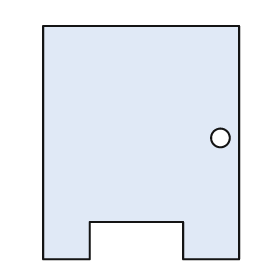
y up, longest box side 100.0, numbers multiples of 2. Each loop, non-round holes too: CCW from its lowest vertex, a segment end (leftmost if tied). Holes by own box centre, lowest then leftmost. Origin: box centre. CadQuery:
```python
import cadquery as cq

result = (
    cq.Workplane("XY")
    .moveTo(-42.0, -50.0)
    .lineTo(-22.0, -50.0)
    .lineTo(-22.0, -34.0)
    .lineTo(18.0, -34.0)
    .lineTo(18.0, -50.0)
    .lineTo(42.0, -50.0)
    .lineTo(42.0, 50.0)
    .lineTo(-42.0, 50.0)
    .close()
    .moveTo(34.0, 2.0)
    .circle(4.0)
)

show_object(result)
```